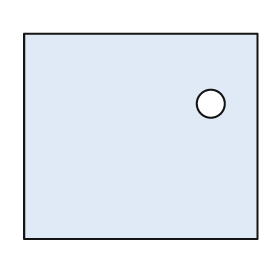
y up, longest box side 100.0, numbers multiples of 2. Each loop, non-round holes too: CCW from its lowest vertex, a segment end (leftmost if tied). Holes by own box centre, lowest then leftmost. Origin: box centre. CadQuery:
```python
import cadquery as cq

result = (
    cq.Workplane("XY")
    .moveTo(-50.0, -44.0)
    .lineTo(50.0, -44.0)
    .lineTo(50.0, 44.0)
    .lineTo(-50.0, 44.0)
    .close()
    .moveTo(30.0, 14.0)
    .circle(6.0)
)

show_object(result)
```